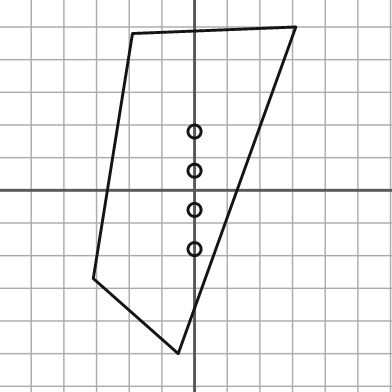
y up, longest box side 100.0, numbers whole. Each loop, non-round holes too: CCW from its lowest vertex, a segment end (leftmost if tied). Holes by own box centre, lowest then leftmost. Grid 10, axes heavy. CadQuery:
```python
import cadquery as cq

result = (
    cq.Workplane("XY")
    .moveTo(-5.0, -50.0)
    .lineTo(31.0, 50.0)
    .lineTo(-19.0, 48.0)
    .lineTo(-31.0, -27.0)
    .close()
    .moveTo(0.0, -18.0)
    .circle(2.0)
    .moveTo(0.0, -6.0)
    .circle(2.0)
    .moveTo(0.0, 6.0)
    .circle(2.0)
    .moveTo(0.0, 18.0)
    .circle(2.0)
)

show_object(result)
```